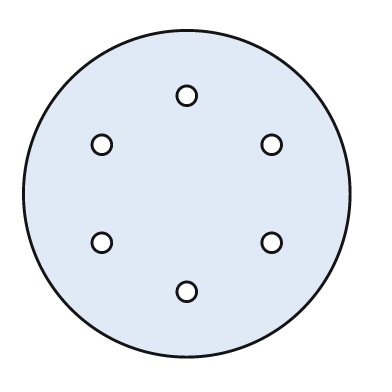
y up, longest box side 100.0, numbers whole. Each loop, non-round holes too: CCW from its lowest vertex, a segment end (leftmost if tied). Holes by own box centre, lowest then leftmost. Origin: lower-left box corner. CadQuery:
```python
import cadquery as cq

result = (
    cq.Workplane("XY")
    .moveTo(50.0, 50.0)
    .circle(50.0)
    .moveTo(50.0, 20.0)
    .circle(3.0)
    .moveTo(24.0, 35.0)
    .circle(3.0)
    .moveTo(76.0, 35.0)
    .circle(3.0)
    .moveTo(24.0, 65.0)
    .circle(3.0)
    .moveTo(76.0, 65.0)
    .circle(3.0)
    .moveTo(50.0, 80.0)
    .circle(3.0)
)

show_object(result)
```